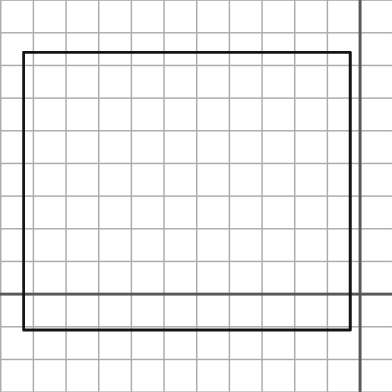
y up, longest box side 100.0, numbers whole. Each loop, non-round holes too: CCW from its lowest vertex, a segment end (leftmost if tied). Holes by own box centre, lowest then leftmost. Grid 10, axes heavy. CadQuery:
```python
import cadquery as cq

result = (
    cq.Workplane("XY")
    .moveTo(-103.0, -11.0)
    .lineTo(-3.0, -11.0)
    .lineTo(-3.0, 74.0)
    .lineTo(-103.0, 74.0)
    .close()
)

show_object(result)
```